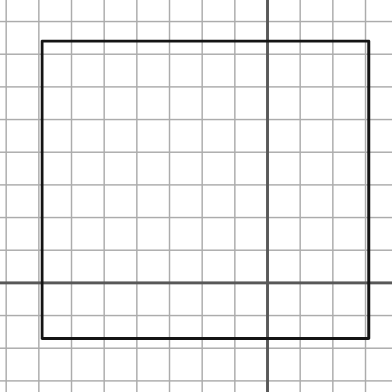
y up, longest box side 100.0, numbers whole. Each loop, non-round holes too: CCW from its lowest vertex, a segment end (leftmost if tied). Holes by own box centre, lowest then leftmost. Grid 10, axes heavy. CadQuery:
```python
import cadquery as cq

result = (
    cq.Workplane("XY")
    .moveTo(-69.0, -17.0)
    .lineTo(31.0, -17.0)
    .lineTo(31.0, 74.0)
    .lineTo(-69.0, 74.0)
    .close()
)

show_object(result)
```